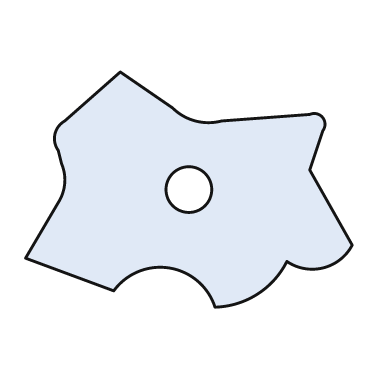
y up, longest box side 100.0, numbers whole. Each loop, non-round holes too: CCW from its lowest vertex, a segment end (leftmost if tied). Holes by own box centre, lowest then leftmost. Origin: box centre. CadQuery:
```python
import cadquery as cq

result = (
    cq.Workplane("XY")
    .moveTo(8.0, -36.0)
    .threePointArc((21.0, -32.0), (30.0, -22.0))
    .threePointArc((41.0, -24.0), (50.0, -17.0))
    .lineTo(37.0, 6.0)
    .lineTo(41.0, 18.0)
    .threePointArc((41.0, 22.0), (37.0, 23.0))
    .lineTo(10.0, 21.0)
    .threePointArc((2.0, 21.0), (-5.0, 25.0))
    .lineTo(-21.0, 36.0)
    .lineTo(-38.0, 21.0)
    .threePointArc((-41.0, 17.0), (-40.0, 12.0))
    .lineTo(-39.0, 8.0)
    .threePointArc((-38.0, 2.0), (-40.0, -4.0))
    .lineTo(-50.0, -21.0)
    .lineTo(-23.0, -31.0)
    .threePointArc((-6.0, -24.0), (8.0, -36.0))
    .close()
    .moveTo(0.0, 0.0)
    .circle(7.0)
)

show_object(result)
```